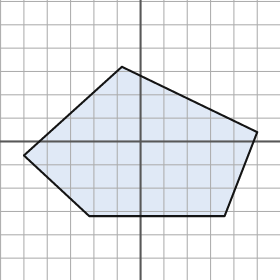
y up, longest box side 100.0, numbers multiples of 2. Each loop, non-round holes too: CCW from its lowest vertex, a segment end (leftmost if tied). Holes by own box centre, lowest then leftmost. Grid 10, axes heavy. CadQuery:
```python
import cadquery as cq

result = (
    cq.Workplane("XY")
    .moveTo(-22.0, -32.0)
    .lineTo(36.0, -32.0)
    .lineTo(50.0, 4.0)
    .lineTo(-8.0, 32.0)
    .lineTo(-50.0, -6.0)
    .close()
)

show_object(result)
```